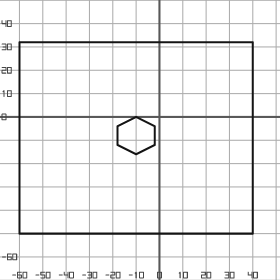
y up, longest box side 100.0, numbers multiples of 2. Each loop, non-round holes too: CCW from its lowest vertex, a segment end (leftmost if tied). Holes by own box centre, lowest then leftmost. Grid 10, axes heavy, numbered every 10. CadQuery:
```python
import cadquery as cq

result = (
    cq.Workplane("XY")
    .moveTo(-60.0, -50.0)
    .lineTo(40.0, -50.0)
    .lineTo(40.0, 32.0)
    .lineTo(-60.0, 32.0)
    .close()
    .moveTo(-10.0, -16.0)
    .lineTo(-2.0, -12.0)
    .lineTo(-2.0, -4.0)
    .lineTo(-10.0, 0.0)
    .lineTo(-18.0, -4.0)
    .lineTo(-18.0, -12.0)
    .close()
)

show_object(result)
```